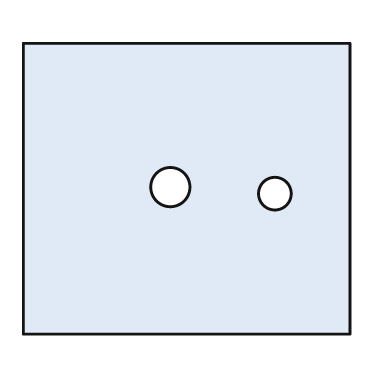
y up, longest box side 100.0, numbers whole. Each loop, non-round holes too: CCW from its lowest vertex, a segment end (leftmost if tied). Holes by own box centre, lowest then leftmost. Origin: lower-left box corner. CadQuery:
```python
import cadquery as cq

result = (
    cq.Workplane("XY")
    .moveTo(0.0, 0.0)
    .lineTo(100.0, 0.0)
    .lineTo(100.0, 89.0)
    .lineTo(0.0, 89.0)
    .close()
    .moveTo(77.0, 43.0)
    .circle(5.0)
    .moveTo(45.0, 45.0)
    .circle(6.0)
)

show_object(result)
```